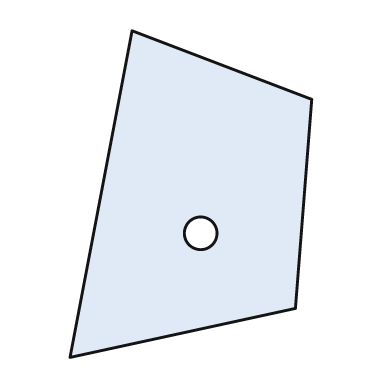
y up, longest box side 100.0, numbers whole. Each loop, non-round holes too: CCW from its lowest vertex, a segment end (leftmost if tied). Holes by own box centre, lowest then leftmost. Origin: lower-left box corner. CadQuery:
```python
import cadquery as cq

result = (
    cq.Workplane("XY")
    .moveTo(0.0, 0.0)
    .lineTo(69.0, 15.0)
    .lineTo(74.0, 79.0)
    .lineTo(19.0, 100.0)
    .close()
    .moveTo(40.0, 38.0)
    .circle(5.0)
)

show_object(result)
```